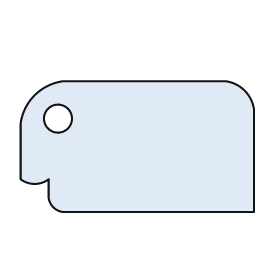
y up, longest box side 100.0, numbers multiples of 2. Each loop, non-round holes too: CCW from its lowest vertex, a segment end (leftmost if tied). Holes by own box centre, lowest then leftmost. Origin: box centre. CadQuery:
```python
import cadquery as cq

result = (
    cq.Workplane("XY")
    .moveTo(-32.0, -28.0)
    .lineTo(50.0, -28.0)
    .lineTo(50.0, 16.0)
    .threePointArc((46.0, 24.0), (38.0, 28.0))
    .lineTo(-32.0, 28.0)
    .threePointArc((-44.0, 22.0), (-50.0, 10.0))
    .lineTo(-50.0, -14.0)
    .threePointArc((-44.0, -16.0), (-38.0, -14.0))
    .lineTo(-38.0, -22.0)
    .threePointArc((-36.0, -26.0), (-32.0, -28.0))
    .close()
    .moveTo(-34.0, 12.0)
    .circle(6.0)
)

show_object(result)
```